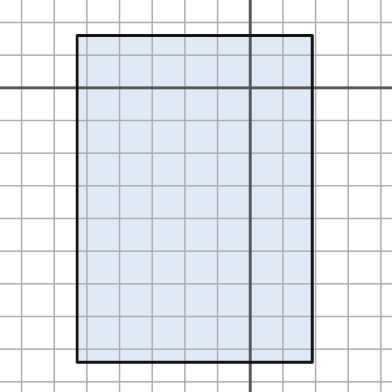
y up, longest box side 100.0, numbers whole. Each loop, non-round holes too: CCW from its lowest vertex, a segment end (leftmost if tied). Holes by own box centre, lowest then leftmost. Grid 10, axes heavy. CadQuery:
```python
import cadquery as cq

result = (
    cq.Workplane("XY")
    .moveTo(-53.0, -84.0)
    .lineTo(19.0, -84.0)
    .lineTo(19.0, 16.0)
    .lineTo(-53.0, 16.0)
    .close()
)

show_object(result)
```